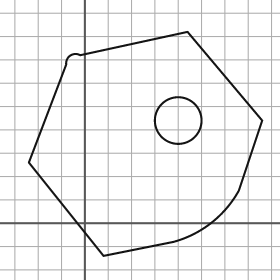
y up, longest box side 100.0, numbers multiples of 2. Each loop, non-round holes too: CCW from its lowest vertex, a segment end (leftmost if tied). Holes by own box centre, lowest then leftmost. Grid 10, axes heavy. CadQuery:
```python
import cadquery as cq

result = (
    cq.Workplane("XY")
    .moveTo(8.0, -14.0)
    .lineTo(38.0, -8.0)
    .threePointArc((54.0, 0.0), (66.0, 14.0))
    .lineTo(76.0, 44.0)
    .lineTo(44.0, 82.0)
    .lineTo(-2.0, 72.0)
    .threePointArc((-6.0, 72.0), (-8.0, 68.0))
    .lineTo(-24.0, 26.0)
    .close()
    .moveTo(40.0, 44.0)
    .circle(10.0)
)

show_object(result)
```